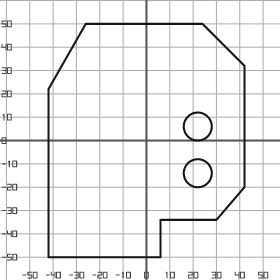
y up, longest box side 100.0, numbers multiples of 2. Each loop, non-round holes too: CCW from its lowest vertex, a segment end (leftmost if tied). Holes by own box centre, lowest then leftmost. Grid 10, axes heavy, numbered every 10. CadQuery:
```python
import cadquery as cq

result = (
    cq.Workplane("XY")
    .moveTo(-42.0, -50.0)
    .lineTo(6.0, -50.0)
    .lineTo(6.0, -34.0)
    .lineTo(30.0, -34.0)
    .lineTo(42.0, -20.0)
    .lineTo(42.0, 32.0)
    .lineTo(24.0, 50.0)
    .lineTo(-26.0, 50.0)
    .lineTo(-42.0, 22.0)
    .close()
    .moveTo(22.0, -14.0)
    .circle(6.0)
    .moveTo(22.0, 6.0)
    .circle(6.0)
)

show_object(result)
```